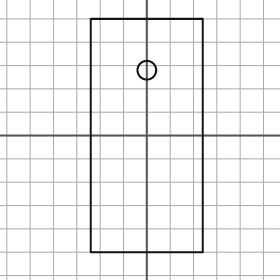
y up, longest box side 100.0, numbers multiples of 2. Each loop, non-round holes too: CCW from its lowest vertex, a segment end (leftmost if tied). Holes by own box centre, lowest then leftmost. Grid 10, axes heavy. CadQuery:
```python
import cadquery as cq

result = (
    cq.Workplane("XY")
    .moveTo(-24.0, -50.0)
    .lineTo(24.0, -50.0)
    .lineTo(24.0, 50.0)
    .lineTo(-24.0, 50.0)
    .close()
    .moveTo(0.0, 28.0)
    .circle(4.0)
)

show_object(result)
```